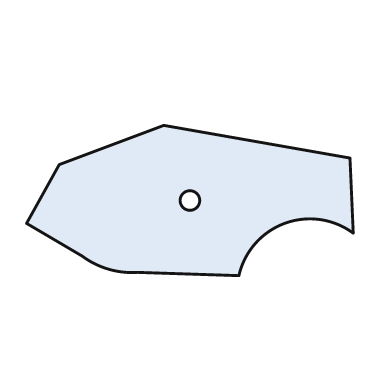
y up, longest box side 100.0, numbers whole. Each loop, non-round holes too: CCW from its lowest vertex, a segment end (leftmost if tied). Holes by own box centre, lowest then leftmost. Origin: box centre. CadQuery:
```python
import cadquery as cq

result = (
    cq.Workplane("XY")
    .moveTo(15.0, -23.0)
    .threePointArc((29.0, -7.0), (50.0, -10.0))
    .lineTo(49.0, 13.0)
    .lineTo(-8.0, 23.0)
    .lineTo(-40.0, 11.0)
    .lineTo(-50.0, -7.0)
    .lineTo(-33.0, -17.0)
    .threePointArc((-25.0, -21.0), (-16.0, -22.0))
    .close()
    .moveTo(0.0, 0.0)
    .circle(3.0)
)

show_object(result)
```